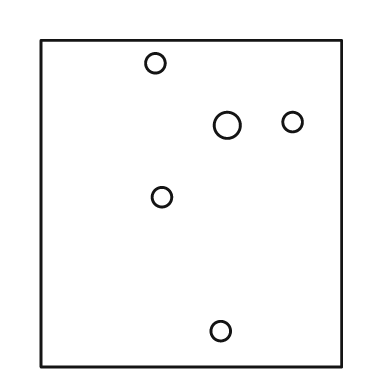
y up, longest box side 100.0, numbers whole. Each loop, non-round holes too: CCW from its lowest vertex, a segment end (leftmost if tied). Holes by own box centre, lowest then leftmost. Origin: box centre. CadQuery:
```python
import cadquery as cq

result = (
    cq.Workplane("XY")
    .moveTo(-46.0, -50.0)
    .lineTo(46.0, -50.0)
    .lineTo(46.0, 50.0)
    .lineTo(-46.0, 50.0)
    .close()
    .moveTo(9.0, -39.0)
    .circle(3.0)
    .moveTo(-9.0, 2.0)
    .circle(3.0)
    .moveTo(11.0, 24.0)
    .circle(4.0)
    .moveTo(31.0, 25.0)
    .circle(3.0)
    .moveTo(-11.0, 43.0)
    .circle(3.0)
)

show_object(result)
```